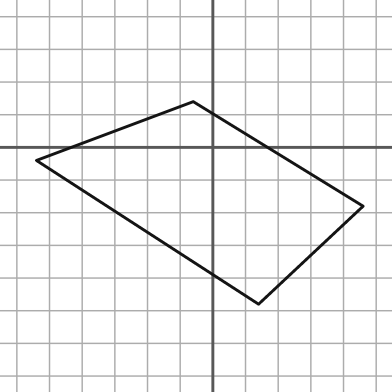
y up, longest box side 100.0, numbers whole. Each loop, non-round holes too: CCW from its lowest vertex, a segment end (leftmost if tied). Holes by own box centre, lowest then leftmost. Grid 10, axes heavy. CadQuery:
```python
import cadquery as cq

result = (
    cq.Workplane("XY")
    .moveTo(14.0, -48.0)
    .lineTo(46.0, -18.0)
    .lineTo(-6.0, 14.0)
    .lineTo(-54.0, -4.0)
    .close()
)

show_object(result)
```